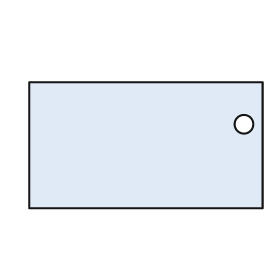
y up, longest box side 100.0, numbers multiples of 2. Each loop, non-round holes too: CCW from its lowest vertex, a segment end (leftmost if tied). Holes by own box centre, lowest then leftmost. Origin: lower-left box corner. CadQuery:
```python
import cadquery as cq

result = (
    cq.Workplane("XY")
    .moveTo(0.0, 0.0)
    .lineTo(100.0, 0.0)
    .lineTo(100.0, 54.0)
    .lineTo(0.0, 54.0)
    .close()
    .moveTo(92.0, 36.0)
    .circle(4.0)
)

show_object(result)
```